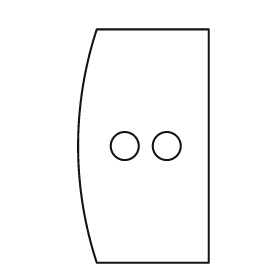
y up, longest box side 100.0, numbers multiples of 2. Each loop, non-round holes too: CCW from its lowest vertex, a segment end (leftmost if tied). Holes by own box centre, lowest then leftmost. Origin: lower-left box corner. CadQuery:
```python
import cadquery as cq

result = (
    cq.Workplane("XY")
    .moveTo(8.0, 0.0)
    .lineTo(56.0, 0.0)
    .lineTo(56.0, 100.0)
    .lineTo(8.0, 100.0)
    .threePointArc((0.0, 50.0), (8.0, 0.0))
    .close()
    .moveTo(20.0, 50.0)
    .circle(6.0)
    .moveTo(38.0, 50.0)
    .circle(6.0)
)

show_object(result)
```